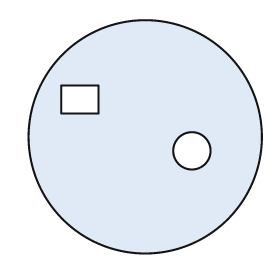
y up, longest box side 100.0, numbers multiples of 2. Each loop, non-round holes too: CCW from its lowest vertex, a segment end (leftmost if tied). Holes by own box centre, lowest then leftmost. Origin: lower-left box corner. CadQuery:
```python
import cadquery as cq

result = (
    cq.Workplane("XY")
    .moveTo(50.0, 50.0)
    .circle(50.0)
    .moveTo(70.0, 44.0)
    .circle(8.0)
    .moveTo(14.0, 60.0)
    .lineTo(30.0, 60.0)
    .lineTo(30.0, 72.0)
    .lineTo(14.0, 72.0)
    .close()
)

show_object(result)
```